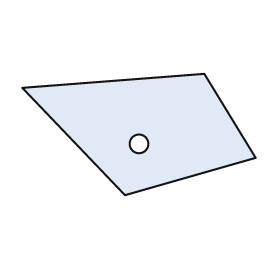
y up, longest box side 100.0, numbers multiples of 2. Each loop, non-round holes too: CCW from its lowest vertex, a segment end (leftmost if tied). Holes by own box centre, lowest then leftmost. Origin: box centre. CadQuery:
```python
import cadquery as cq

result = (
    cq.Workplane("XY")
    .moveTo(-6.0, -26.0)
    .lineTo(50.0, -10.0)
    .lineTo(28.0, 26.0)
    .lineTo(-50.0, 20.0)
    .close()
    .moveTo(0.0, -4.0)
    .circle(4.0)
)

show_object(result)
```